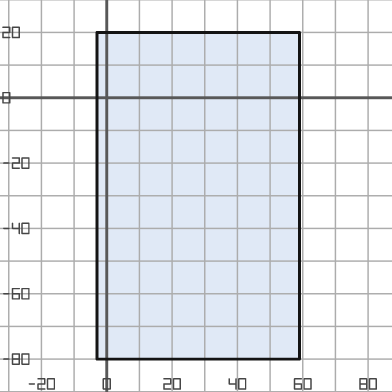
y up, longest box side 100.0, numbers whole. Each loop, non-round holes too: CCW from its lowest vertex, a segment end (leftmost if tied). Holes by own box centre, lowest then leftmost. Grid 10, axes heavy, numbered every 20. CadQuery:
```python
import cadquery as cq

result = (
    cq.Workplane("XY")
    .moveTo(-3.0, -80.0)
    .lineTo(59.0, -80.0)
    .lineTo(59.0, 20.0)
    .lineTo(-3.0, 20.0)
    .close()
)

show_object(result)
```